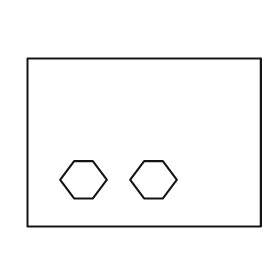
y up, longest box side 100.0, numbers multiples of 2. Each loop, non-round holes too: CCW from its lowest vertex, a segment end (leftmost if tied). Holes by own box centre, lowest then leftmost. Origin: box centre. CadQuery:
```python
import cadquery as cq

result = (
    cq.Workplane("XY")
    .moveTo(-50.0, -36.0)
    .lineTo(50.0, -36.0)
    .lineTo(50.0, 36.0)
    .lineTo(-50.0, 36.0)
    .close()
    .moveTo(-30.0, -24.0)
    .lineTo(-22.0, -24.0)
    .lineTo(-16.0, -16.0)
    .lineTo(-22.0, -8.0)
    .lineTo(-30.0, -8.0)
    .lineTo(-36.0, -16.0)
    .close()
    .moveTo(0.0, -24.0)
    .lineTo(8.0, -24.0)
    .lineTo(14.0, -16.0)
    .lineTo(8.0, -8.0)
    .lineTo(0.0, -8.0)
    .lineTo(-6.0, -16.0)
    .close()
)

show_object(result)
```